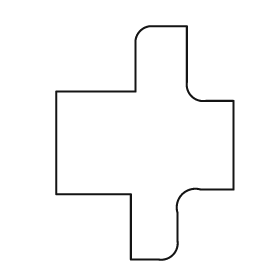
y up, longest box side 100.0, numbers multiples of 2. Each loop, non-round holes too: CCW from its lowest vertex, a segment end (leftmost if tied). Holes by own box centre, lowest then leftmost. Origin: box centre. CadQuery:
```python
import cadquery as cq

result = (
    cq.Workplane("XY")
    .moveTo(-6.0, -50.0)
    .lineTo(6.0, -50.0)
    .threePointArc((12.0, -48.0), (14.0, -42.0))
    .lineTo(14.0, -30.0)
    .threePointArc((16.0, -22.0), (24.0, -20.0))
    .lineTo(38.0, -20.0)
    .lineTo(38.0, 18.0)
    .lineTo(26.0, 18.0)
    .threePointArc((20.0, 20.0), (18.0, 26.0))
    .lineTo(18.0, 50.0)
    .lineTo(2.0, 50.0)
    .threePointArc((-2.0, 48.0), (-4.0, 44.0))
    .lineTo(-4.0, 22.0)
    .lineTo(-38.0, 22.0)
    .lineTo(-38.0, -22.0)
    .lineTo(-6.0, -22.0)
    .close()
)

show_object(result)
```